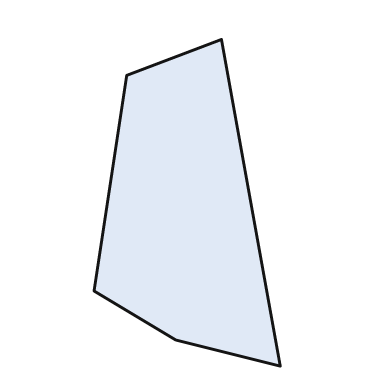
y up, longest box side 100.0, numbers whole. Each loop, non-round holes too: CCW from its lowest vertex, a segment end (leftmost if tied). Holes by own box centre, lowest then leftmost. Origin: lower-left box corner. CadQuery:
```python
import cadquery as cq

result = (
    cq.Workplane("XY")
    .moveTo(57.0, 0.0)
    .lineTo(39.0, 100.0)
    .lineTo(10.0, 89.0)
    .lineTo(0.0, 23.0)
    .lineTo(25.0, 8.0)
    .close()
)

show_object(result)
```